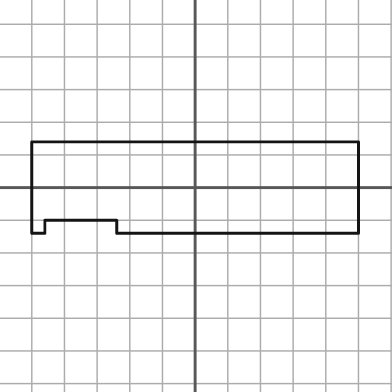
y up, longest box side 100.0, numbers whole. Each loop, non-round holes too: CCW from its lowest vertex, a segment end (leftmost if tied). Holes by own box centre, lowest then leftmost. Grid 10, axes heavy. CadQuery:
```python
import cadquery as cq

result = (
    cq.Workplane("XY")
    .moveTo(-50.0, -14.0)
    .lineTo(-46.0, -14.0)
    .lineTo(-46.0, -10.0)
    .lineTo(-24.0, -10.0)
    .lineTo(-24.0, -14.0)
    .lineTo(50.0, -14.0)
    .lineTo(50.0, 14.0)
    .lineTo(-50.0, 14.0)
    .close()
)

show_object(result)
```